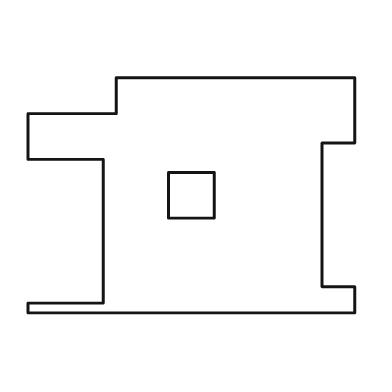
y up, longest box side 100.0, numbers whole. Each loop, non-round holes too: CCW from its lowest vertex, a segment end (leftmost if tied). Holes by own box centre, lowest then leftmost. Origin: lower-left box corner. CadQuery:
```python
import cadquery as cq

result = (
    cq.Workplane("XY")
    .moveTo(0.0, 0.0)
    .lineTo(100.0, 0.0)
    .lineTo(100.0, 8.0)
    .lineTo(90.0, 8.0)
    .lineTo(90.0, 52.0)
    .lineTo(100.0, 52.0)
    .lineTo(100.0, 72.0)
    .lineTo(27.0, 72.0)
    .lineTo(27.0, 61.0)
    .lineTo(0.0, 61.0)
    .lineTo(0.0, 47.0)
    .lineTo(23.0, 47.0)
    .lineTo(23.0, 3.0)
    .lineTo(0.0, 3.0)
    .close()
    .moveTo(43.0, 29.0)
    .lineTo(57.0, 29.0)
    .lineTo(57.0, 43.0)
    .lineTo(43.0, 43.0)
    .close()
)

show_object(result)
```